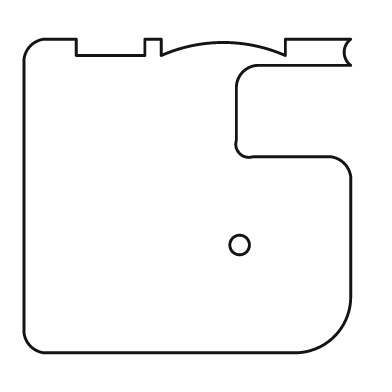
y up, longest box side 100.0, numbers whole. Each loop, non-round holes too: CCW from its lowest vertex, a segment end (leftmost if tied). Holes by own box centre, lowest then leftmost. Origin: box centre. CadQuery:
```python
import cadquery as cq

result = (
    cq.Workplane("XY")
    .moveTo(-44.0, -48.0)
    .lineTo(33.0, -48.0)
    .threePointArc((45.0, -43.0), (50.0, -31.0))
    .lineTo(50.0, 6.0)
    .threePointArc((48.0, 10.0), (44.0, 12.0))
    .lineTo(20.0, 12.0)
    .threePointArc((16.0, 13.0), (15.0, 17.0))
    .lineTo(15.0, 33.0)
    .threePointArc((17.0, 38.0), (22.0, 40.0))
    .lineTo(50.0, 40.0)
    .threePointArc((48.0, 44.0), (50.0, 48.0))
    .lineTo(30.0, 48.0)
    .lineTo(30.0, 43.0)
    .threePointArc((11.0, 47.0), (-8.0, 43.0))
    .lineTo(-8.0, 48.0)
    .lineTo(-13.0, 48.0)
    .lineTo(-13.0, 43.0)
    .lineTo(-34.0, 43.0)
    .lineTo(-34.0, 48.0)
    .lineTo(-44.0, 48.0)
    .threePointArc((-48.0, 46.0), (-50.0, 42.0))
    .lineTo(-50.0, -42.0)
    .threePointArc((-48.0, -46.0), (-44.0, -48.0))
    .close()
    .moveTo(16.0, -15.0)
    .circle(3.0)
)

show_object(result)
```